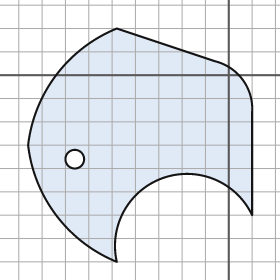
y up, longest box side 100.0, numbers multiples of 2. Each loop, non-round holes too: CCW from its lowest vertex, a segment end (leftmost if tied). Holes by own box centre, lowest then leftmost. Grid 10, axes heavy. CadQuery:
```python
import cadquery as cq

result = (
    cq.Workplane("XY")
    .moveTo(-48.0, -80.0)
    .threePointArc((-28.0, -44.0), (10.0, -60.0))
    .lineTo(10.0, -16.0)
    .threePointArc((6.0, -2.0), (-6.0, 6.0))
    .lineTo(-48.0, 20.0)
    .threePointArc((-74.0, 0.0), (-86.0, -30.0))
    .threePointArc((-74.0, -60.0), (-48.0, -80.0))
    .close()
    .moveTo(-66.0, -36.0)
    .circle(4.0)
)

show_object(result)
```